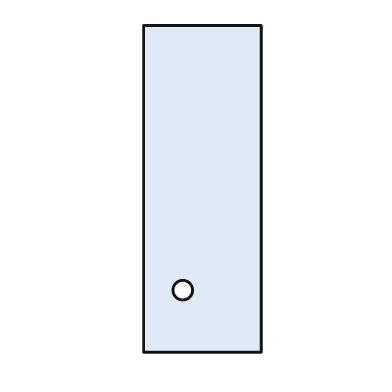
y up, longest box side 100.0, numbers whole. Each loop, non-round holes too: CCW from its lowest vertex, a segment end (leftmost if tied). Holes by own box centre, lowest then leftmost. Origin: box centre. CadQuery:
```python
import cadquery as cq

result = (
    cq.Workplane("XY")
    .moveTo(-18.0, -50.0)
    .lineTo(18.0, -50.0)
    .lineTo(18.0, 50.0)
    .lineTo(-18.0, 50.0)
    .close()
    .moveTo(-6.0, -31.0)
    .circle(3.0)
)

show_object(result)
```